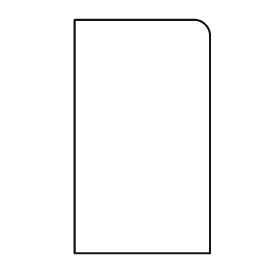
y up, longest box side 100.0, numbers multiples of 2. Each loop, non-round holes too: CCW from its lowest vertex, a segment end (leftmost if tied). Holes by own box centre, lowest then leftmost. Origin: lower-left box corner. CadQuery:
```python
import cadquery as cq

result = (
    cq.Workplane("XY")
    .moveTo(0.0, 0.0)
    .lineTo(58.0, 0.0)
    .lineTo(58.0, 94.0)
    .threePointArc((56.0, 98.0), (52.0, 100.0))
    .lineTo(0.0, 100.0)
    .close()
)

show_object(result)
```